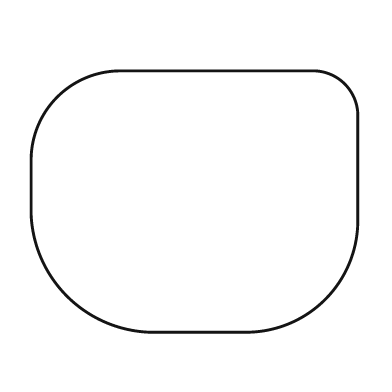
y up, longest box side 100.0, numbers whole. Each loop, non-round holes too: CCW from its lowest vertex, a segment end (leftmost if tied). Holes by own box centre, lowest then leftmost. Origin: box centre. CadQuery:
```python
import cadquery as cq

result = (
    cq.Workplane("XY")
    .moveTo(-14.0, -40.0)
    .lineTo(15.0, -40.0)
    .threePointArc((40.0, -30.0), (50.0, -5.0))
    .lineTo(50.0, 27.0)
    .threePointArc((46.0, 36.0), (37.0, 40.0))
    .lineTo(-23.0, 40.0)
    .threePointArc((-42.0, 32.0), (-50.0, 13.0))
    .lineTo(-50.0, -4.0)
    .threePointArc((-39.0, -29.0), (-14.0, -40.0))
    .close()
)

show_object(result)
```